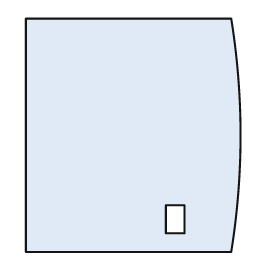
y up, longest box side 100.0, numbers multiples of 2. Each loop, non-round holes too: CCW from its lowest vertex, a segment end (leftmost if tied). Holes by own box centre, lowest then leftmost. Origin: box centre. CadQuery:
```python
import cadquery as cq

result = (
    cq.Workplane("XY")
    .moveTo(-46.0, -50.0)
    .lineTo(42.0, -50.0)
    .threePointArc((46.0, 0.0), (42.0, 50.0))
    .lineTo(-46.0, 50.0)
    .close()
    .moveTo(14.0, -42.0)
    .lineTo(22.0, -42.0)
    .lineTo(22.0, -30.0)
    .lineTo(14.0, -30.0)
    .close()
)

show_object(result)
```